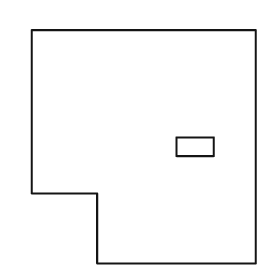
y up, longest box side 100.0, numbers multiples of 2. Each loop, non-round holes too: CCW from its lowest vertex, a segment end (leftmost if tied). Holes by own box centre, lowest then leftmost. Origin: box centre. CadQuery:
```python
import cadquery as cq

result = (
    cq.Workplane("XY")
    .moveTo(-20.0, -50.0)
    .lineTo(48.0, -50.0)
    .lineTo(48.0, 50.0)
    .lineTo(-48.0, 50.0)
    .lineTo(-48.0, -20.0)
    .lineTo(-20.0, -20.0)
    .close()
    .moveTo(14.0, -4.0)
    .lineTo(30.0, -4.0)
    .lineTo(30.0, 4.0)
    .lineTo(14.0, 4.0)
    .close()
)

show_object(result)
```